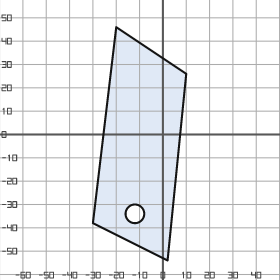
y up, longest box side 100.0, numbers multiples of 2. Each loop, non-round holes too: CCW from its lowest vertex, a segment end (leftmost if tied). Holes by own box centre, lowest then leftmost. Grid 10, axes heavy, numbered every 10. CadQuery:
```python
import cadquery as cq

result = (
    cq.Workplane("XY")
    .moveTo(2.0, -54.0)
    .lineTo(10.0, 26.0)
    .lineTo(-20.0, 46.0)
    .lineTo(-30.0, -38.0)
    .close()
    .moveTo(-12.0, -34.0)
    .circle(4.0)
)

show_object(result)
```